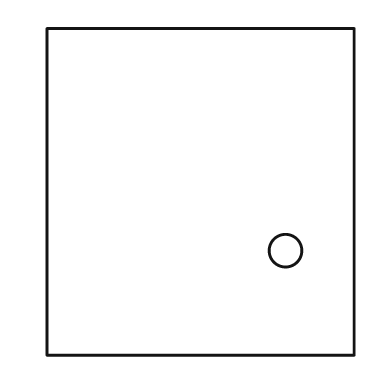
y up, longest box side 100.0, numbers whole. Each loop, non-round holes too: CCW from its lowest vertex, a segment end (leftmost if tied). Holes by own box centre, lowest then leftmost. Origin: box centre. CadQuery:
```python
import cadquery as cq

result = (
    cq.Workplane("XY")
    .moveTo(-47.0, -50.0)
    .lineTo(47.0, -50.0)
    .lineTo(47.0, 50.0)
    .lineTo(-47.0, 50.0)
    .close()
    .moveTo(26.0, -18.0)
    .circle(5.0)
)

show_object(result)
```